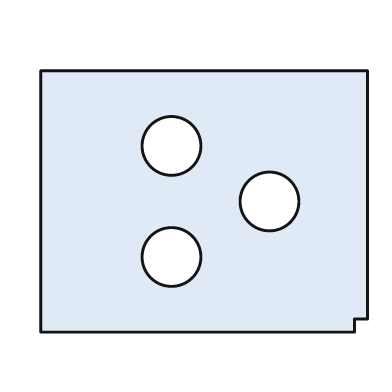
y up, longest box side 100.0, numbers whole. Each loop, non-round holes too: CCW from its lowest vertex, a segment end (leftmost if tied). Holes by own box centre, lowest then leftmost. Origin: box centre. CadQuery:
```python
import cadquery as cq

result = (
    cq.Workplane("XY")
    .moveTo(-50.0, -40.0)
    .lineTo(46.0, -40.0)
    .lineTo(46.0, -36.0)
    .lineTo(50.0, -36.0)
    .lineTo(50.0, 40.0)
    .lineTo(-50.0, 40.0)
    .close()
    .moveTo(-10.0, -17.0)
    .circle(9.0)
    .moveTo(20.0, 0.0)
    .circle(9.0)
    .moveTo(-10.0, 17.0)
    .circle(9.0)
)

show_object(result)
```